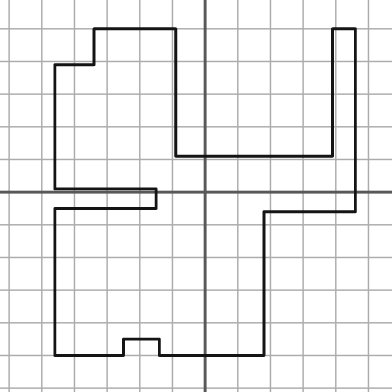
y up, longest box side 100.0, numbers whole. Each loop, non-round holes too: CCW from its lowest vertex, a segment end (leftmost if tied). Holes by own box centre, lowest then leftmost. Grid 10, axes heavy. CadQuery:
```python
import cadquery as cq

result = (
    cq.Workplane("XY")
    .moveTo(-46.0, -50.0)
    .lineTo(-25.0, -50.0)
    .lineTo(-25.0, -45.0)
    .lineTo(-14.0, -45.0)
    .lineTo(-14.0, -50.0)
    .lineTo(18.0, -50.0)
    .lineTo(18.0, -6.0)
    .lineTo(46.0, -6.0)
    .lineTo(46.0, 50.0)
    .lineTo(39.0, 50.0)
    .lineTo(39.0, 11.0)
    .lineTo(-9.0, 11.0)
    .lineTo(-9.0, 50.0)
    .lineTo(-34.0, 50.0)
    .lineTo(-34.0, 39.0)
    .lineTo(-46.0, 39.0)
    .lineTo(-46.0, 1.0)
    .lineTo(-15.0, 1.0)
    .lineTo(-15.0, -5.0)
    .lineTo(-46.0, -5.0)
    .close()
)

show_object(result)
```